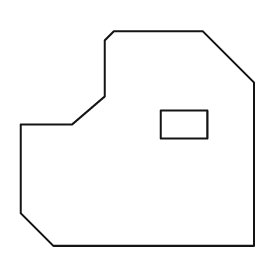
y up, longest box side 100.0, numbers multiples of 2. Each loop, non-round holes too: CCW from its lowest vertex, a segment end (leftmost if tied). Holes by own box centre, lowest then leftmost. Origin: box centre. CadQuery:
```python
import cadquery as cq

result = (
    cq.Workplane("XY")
    .moveTo(-36.0, -46.0)
    .lineTo(50.0, -46.0)
    .lineTo(50.0, 24.0)
    .lineTo(28.0, 46.0)
    .lineTo(-10.0, 46.0)
    .lineTo(-14.0, 42.0)
    .lineTo(-14.0, 18.0)
    .lineTo(-28.0, 6.0)
    .lineTo(-50.0, 6.0)
    .lineTo(-50.0, -32.0)
    .close()
    .moveTo(10.0, 0.0)
    .lineTo(30.0, 0.0)
    .lineTo(30.0, 12.0)
    .lineTo(10.0, 12.0)
    .close()
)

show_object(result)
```